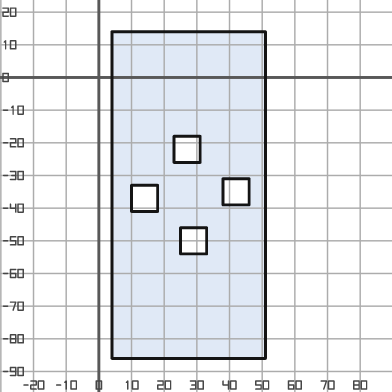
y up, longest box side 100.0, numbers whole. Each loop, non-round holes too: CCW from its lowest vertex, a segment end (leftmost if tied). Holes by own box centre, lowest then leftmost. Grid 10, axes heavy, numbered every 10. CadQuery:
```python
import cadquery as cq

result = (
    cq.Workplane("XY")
    .moveTo(4.0, -86.0)
    .lineTo(51.0, -86.0)
    .lineTo(51.0, 14.0)
    .lineTo(4.0, 14.0)
    .close()
    .moveTo(25.0, -54.0)
    .lineTo(33.0, -54.0)
    .lineTo(33.0, -46.0)
    .lineTo(25.0, -46.0)
    .close()
    .moveTo(10.0, -41.0)
    .lineTo(18.0, -41.0)
    .lineTo(18.0, -33.0)
    .lineTo(10.0, -33.0)
    .close()
    .moveTo(38.0, -39.0)
    .lineTo(46.0, -39.0)
    .lineTo(46.0, -31.0)
    .lineTo(38.0, -31.0)
    .close()
    .moveTo(23.0, -26.0)
    .lineTo(31.0, -26.0)
    .lineTo(31.0, -18.0)
    .lineTo(23.0, -18.0)
    .close()
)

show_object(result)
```